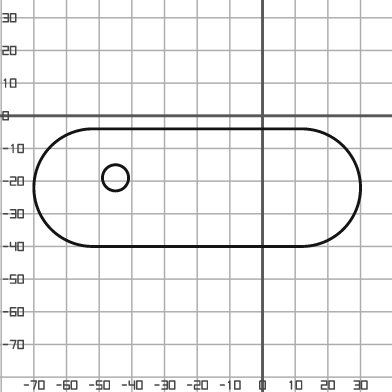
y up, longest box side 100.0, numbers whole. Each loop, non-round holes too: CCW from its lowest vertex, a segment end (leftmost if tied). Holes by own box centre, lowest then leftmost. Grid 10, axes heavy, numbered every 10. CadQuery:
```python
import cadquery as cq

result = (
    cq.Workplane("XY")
    .moveTo(-52.0, -40.0)
    .lineTo(12.0, -40.0)
    .threePointArc((30.0, -22.0), (12.0, -4.0))
    .lineTo(-52.0, -4.0)
    .threePointArc((-70.0, -22.0), (-52.0, -40.0))
    .close()
    .moveTo(-45.0, -19.0)
    .circle(4.0)
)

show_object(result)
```